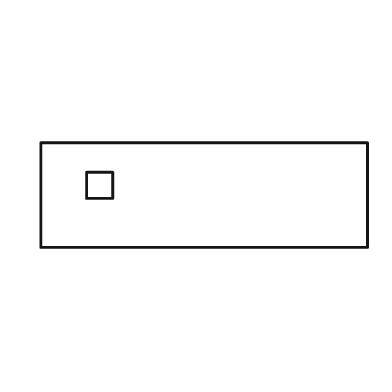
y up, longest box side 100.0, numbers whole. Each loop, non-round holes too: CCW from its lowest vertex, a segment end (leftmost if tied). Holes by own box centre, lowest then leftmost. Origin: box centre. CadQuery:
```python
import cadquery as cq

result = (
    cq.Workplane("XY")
    .moveTo(-50.0, -16.0)
    .lineTo(50.0, -16.0)
    .lineTo(50.0, 16.0)
    .lineTo(-50.0, 16.0)
    .close()
    .moveTo(-36.0, -1.0)
    .lineTo(-28.0, -1.0)
    .lineTo(-28.0, 7.0)
    .lineTo(-36.0, 7.0)
    .close()
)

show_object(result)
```